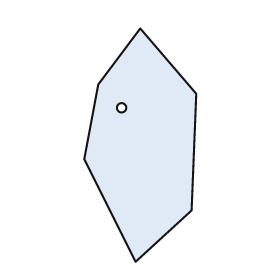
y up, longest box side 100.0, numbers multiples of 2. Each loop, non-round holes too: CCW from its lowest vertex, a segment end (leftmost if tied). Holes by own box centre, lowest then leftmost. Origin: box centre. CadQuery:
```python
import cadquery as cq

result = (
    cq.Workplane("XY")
    .moveTo(-2.0, -50.0)
    .lineTo(22.0, -28.0)
    .lineTo(24.0, 22.0)
    .lineTo(0.0, 50.0)
    .lineTo(-18.0, 26.0)
    .lineTo(-24.0, -6.0)
    .close()
    .moveTo(-8.0, 16.0)
    .circle(2.0)
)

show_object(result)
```